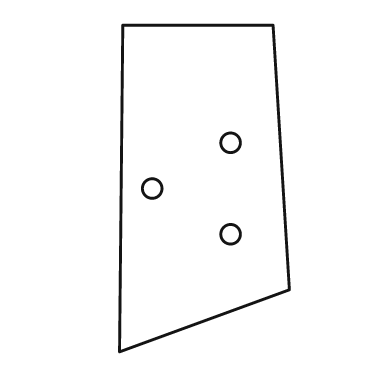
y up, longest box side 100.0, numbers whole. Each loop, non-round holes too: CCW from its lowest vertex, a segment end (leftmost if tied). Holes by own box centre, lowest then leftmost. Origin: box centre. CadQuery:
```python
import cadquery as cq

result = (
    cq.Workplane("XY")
    .moveTo(-26.0, -50.0)
    .lineTo(26.0, -31.0)
    .lineTo(21.0, 50.0)
    .lineTo(-25.0, 50.0)
    .close()
    .moveTo(8.0, -14.0)
    .circle(3.0)
    .moveTo(-16.0, 0.0)
    .circle(3.0)
    .moveTo(8.0, 14.0)
    .circle(3.0)
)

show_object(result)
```